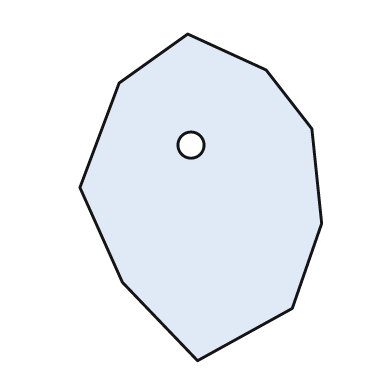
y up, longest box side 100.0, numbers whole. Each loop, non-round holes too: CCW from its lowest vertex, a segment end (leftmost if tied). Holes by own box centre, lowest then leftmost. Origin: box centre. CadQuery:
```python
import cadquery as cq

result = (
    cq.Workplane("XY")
    .moveTo(-1.0, -50.0)
    .lineTo(28.0, -34.0)
    .lineTo(37.0, -8.0)
    .lineTo(34.0, 21.0)
    .lineTo(20.0, 39.0)
    .lineTo(-4.0, 50.0)
    .lineTo(-25.0, 35.0)
    .lineTo(-37.0, 3.0)
    .lineTo(-24.0, -26.0)
    .close()
    .moveTo(-3.0, 16.0)
    .circle(4.0)
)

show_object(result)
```